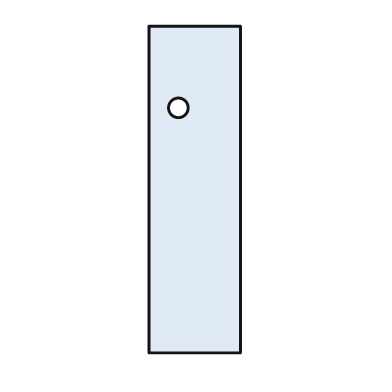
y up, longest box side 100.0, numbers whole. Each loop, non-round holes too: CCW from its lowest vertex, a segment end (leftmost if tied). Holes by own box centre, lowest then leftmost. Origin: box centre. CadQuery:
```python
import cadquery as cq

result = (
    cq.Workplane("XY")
    .moveTo(-14.0, -50.0)
    .lineTo(14.0, -50.0)
    .lineTo(14.0, 50.0)
    .lineTo(-14.0, 50.0)
    .close()
    .moveTo(-5.0, 25.0)
    .circle(3.0)
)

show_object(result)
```